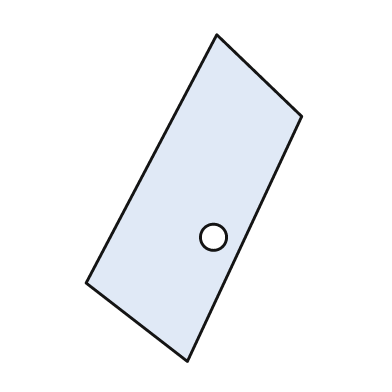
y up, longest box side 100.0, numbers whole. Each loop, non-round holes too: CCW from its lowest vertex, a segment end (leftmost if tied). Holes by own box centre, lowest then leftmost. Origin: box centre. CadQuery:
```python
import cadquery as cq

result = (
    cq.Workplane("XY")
    .moveTo(-2.0, -50.0)
    .lineTo(33.0, 25.0)
    .lineTo(7.0, 50.0)
    .lineTo(-33.0, -26.0)
    .close()
    .moveTo(6.0, -12.0)
    .circle(4.0)
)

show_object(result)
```